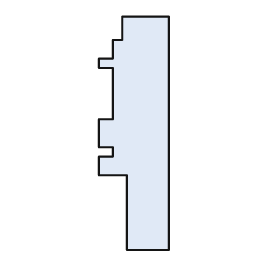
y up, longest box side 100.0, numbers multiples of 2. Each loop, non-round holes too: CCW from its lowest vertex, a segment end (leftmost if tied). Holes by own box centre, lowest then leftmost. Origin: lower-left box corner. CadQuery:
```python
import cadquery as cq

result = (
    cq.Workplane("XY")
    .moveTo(12.0, 0.0)
    .lineTo(30.0, 0.0)
    .lineTo(30.0, 100.0)
    .lineTo(10.0, 100.0)
    .lineTo(10.0, 90.0)
    .lineTo(6.0, 90.0)
    .lineTo(6.0, 82.0)
    .lineTo(0.0, 82.0)
    .lineTo(0.0, 78.0)
    .lineTo(6.0, 78.0)
    .lineTo(6.0, 56.0)
    .lineTo(0.0, 56.0)
    .lineTo(0.0, 44.0)
    .lineTo(6.0, 44.0)
    .lineTo(6.0, 40.0)
    .lineTo(0.0, 40.0)
    .lineTo(0.0, 32.0)
    .lineTo(12.0, 32.0)
    .close()
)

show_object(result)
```